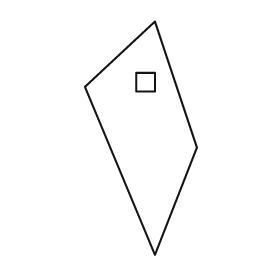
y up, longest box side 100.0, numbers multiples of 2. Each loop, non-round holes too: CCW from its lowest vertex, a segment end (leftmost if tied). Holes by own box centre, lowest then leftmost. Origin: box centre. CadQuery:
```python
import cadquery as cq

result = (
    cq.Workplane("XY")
    .moveTo(6.0, -50.0)
    .lineTo(24.0, -4.0)
    .lineTo(6.0, 50.0)
    .lineTo(-24.0, 22.0)
    .close()
    .moveTo(-2.0, 20.0)
    .lineTo(6.0, 20.0)
    .lineTo(6.0, 28.0)
    .lineTo(-2.0, 28.0)
    .close()
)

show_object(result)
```